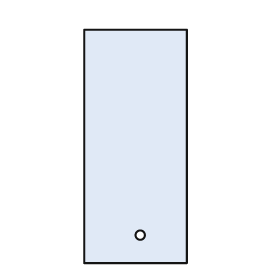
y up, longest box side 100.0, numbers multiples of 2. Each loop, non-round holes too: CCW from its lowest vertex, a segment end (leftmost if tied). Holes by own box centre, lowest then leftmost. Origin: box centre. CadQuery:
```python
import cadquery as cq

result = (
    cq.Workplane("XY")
    .moveTo(-22.0, -50.0)
    .lineTo(22.0, -50.0)
    .lineTo(22.0, 50.0)
    .lineTo(-22.0, 50.0)
    .close()
    .moveTo(2.0, -38.0)
    .circle(2.0)
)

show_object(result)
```